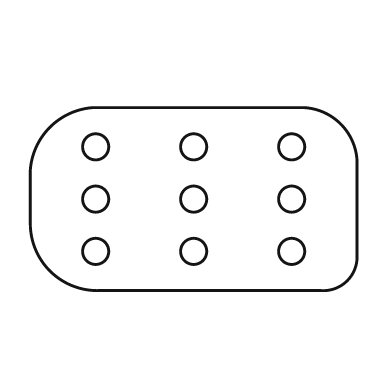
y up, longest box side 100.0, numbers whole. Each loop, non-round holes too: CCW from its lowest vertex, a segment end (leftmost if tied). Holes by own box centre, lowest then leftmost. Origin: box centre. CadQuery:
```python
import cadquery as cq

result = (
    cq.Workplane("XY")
    .moveTo(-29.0, -28.0)
    .lineTo(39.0, -28.0)
    .threePointArc((47.0, -25.0), (50.0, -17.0))
    .lineTo(50.0, 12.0)
    .threePointArc((45.0, 23.0), (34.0, 28.0))
    .lineTo(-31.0, 28.0)
    .threePointArc((-44.0, 22.0), (-50.0, 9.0))
    .lineTo(-50.0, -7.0)
    .threePointArc((-44.0, -22.0), (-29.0, -28.0))
    .close()
    .moveTo(-30.0, -16.0)
    .circle(4.0)
    .moveTo(0.0, -16.0)
    .circle(4.0)
    .moveTo(30.0, -16.0)
    .circle(4.0)
    .moveTo(-30.0, 0.0)
    .circle(4.0)
    .moveTo(0.0, 0.0)
    .circle(4.0)
    .moveTo(30.0, 0.0)
    .circle(4.0)
    .moveTo(-30.0, 16.0)
    .circle(4.0)
    .moveTo(0.0, 16.0)
    .circle(4.0)
    .moveTo(30.0, 16.0)
    .circle(4.0)
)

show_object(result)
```